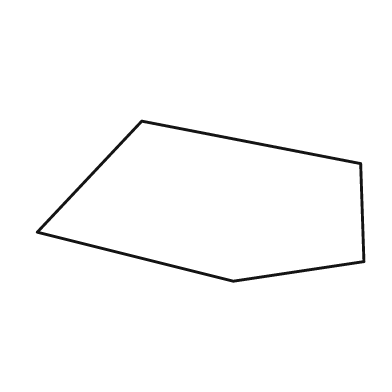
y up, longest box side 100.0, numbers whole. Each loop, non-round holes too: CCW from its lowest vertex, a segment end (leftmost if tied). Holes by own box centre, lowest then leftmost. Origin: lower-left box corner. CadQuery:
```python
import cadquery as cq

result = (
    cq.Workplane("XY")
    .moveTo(60.0, 0.0)
    .lineTo(100.0, 6.0)
    .lineTo(99.0, 36.0)
    .lineTo(32.0, 49.0)
    .lineTo(0.0, 15.0)
    .close()
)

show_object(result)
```